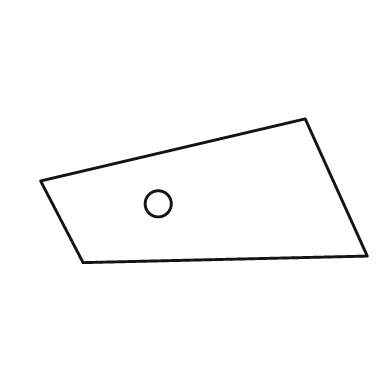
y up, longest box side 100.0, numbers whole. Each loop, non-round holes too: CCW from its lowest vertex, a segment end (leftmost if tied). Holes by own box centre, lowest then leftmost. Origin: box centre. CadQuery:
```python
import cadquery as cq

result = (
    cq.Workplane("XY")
    .moveTo(-37.0, -22.0)
    .lineTo(50.0, -20.0)
    .lineTo(31.0, 22.0)
    .lineTo(-50.0, 3.0)
    .close()
    .moveTo(-14.0, -4.0)
    .circle(4.0)
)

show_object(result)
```